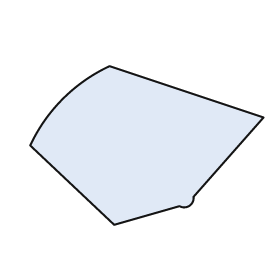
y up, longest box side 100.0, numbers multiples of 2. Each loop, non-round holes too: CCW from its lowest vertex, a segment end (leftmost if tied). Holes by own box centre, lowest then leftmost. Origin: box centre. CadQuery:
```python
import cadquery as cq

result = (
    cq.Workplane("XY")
    .moveTo(-14.0, -34.0)
    .lineTo(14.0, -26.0)
    .threePointArc((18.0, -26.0), (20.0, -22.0))
    .lineTo(50.0, 12.0)
    .lineTo(-16.0, 34.0)
    .threePointArc((-36.0, 20.0), (-50.0, 0.0))
    .close()
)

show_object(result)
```